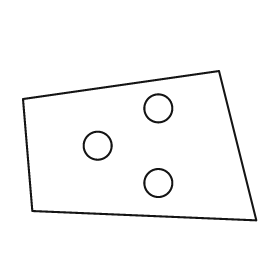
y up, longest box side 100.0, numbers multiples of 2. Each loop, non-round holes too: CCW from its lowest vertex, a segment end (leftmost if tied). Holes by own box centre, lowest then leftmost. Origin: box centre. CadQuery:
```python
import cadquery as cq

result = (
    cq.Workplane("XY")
    .moveTo(50.0, -32.0)
    .lineTo(34.0, 32.0)
    .lineTo(-50.0, 20.0)
    .lineTo(-46.0, -28.0)
    .close()
    .moveTo(8.0, -16.0)
    .circle(6.0)
    .moveTo(-18.0, 0.0)
    .circle(6.0)
    .moveTo(8.0, 16.0)
    .circle(6.0)
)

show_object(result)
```